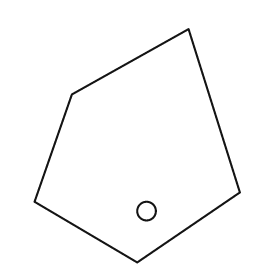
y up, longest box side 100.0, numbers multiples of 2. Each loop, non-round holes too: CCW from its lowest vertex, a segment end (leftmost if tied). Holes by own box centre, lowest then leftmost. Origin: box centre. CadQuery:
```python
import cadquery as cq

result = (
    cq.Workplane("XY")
    .moveTo(0.0, -50.0)
    .lineTo(44.0, -20.0)
    .lineTo(22.0, 50.0)
    .lineTo(-28.0, 22.0)
    .lineTo(-44.0, -24.0)
    .close()
    .moveTo(4.0, -28.0)
    .circle(4.0)
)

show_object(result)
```